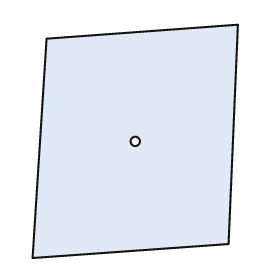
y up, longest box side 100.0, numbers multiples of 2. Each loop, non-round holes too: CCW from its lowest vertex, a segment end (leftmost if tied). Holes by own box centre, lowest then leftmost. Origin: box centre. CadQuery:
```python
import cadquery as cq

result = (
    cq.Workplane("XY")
    .moveTo(-44.0, -50.0)
    .lineTo(40.0, -44.0)
    .lineTo(44.0, 50.0)
    .lineTo(-38.0, 44.0)
    .close()
    .moveTo(0.0, 0.0)
    .circle(2.0)
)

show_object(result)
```